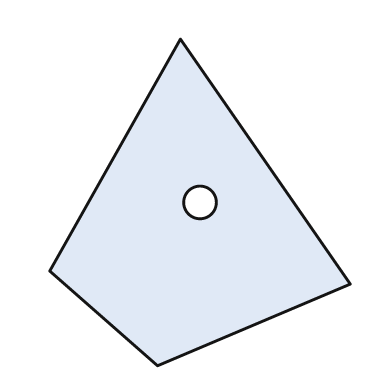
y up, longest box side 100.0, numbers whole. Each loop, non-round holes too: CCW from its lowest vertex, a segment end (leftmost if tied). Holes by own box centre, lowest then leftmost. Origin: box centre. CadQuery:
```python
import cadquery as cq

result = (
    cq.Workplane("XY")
    .moveTo(-13.0, -50.0)
    .lineTo(46.0, -25.0)
    .lineTo(-6.0, 50.0)
    .lineTo(-46.0, -21.0)
    .close()
    .moveTo(0.0, 0.0)
    .circle(5.0)
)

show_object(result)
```